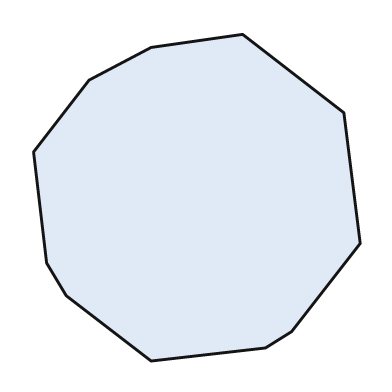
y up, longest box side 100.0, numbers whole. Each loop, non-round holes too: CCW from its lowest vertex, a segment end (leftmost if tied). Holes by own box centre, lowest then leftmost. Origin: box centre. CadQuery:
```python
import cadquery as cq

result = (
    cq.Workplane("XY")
    .moveTo(-14.0, -50.0)
    .lineTo(21.0, -46.0)
    .lineTo(29.0, -41.0)
    .lineTo(50.0, -14.0)
    .lineTo(45.0, 26.0)
    .lineTo(14.0, 50.0)
    .lineTo(-14.0, 46.0)
    .lineTo(-33.0, 36.0)
    .lineTo(-50.0, 14.0)
    .lineTo(-46.0, -20.0)
    .lineTo(-40.0, -30.0)
    .close()
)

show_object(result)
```